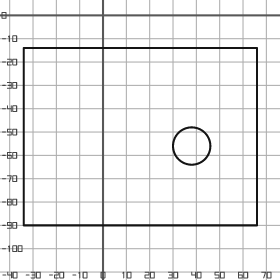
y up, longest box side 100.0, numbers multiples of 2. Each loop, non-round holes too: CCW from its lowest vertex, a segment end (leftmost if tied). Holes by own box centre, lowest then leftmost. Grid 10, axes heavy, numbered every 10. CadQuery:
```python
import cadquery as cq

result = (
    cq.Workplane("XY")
    .moveTo(-34.0, -90.0)
    .lineTo(66.0, -90.0)
    .lineTo(66.0, -14.0)
    .lineTo(-34.0, -14.0)
    .close()
    .moveTo(38.0, -56.0)
    .circle(8.0)
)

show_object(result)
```